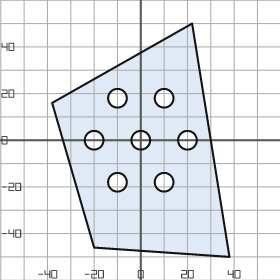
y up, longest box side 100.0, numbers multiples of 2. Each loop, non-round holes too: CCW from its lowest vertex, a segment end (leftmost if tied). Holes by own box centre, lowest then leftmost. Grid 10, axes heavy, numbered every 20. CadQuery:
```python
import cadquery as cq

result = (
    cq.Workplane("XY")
    .moveTo(38.0, -50.0)
    .lineTo(22.0, 50.0)
    .lineTo(-38.0, 16.0)
    .lineTo(-20.0, -46.0)
    .close()
    .moveTo(-10.0, -18.0)
    .circle(4.0)
    .moveTo(10.0, -18.0)
    .circle(4.0)
    .moveTo(-20.0, 0.0)
    .circle(4.0)
    .moveTo(0.0, 0.0)
    .circle(4.0)
    .moveTo(20.0, 0.0)
    .circle(4.0)
    .moveTo(-10.0, 18.0)
    .circle(4.0)
    .moveTo(10.0, 18.0)
    .circle(4.0)
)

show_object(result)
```